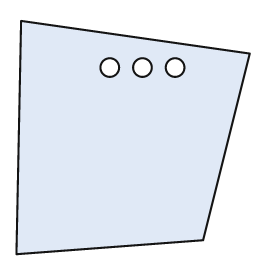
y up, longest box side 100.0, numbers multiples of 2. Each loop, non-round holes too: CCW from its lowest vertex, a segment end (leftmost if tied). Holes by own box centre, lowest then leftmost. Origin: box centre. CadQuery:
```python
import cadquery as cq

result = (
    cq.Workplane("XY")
    .moveTo(-50.0, -50.0)
    .lineTo(30.0, -44.0)
    .lineTo(50.0, 36.0)
    .lineTo(-48.0, 50.0)
    .close()
    .moveTo(-10.0, 30.0)
    .circle(4.0)
    .moveTo(4.0, 30.0)
    .circle(4.0)
    .moveTo(18.0, 30.0)
    .circle(4.0)
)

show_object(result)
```